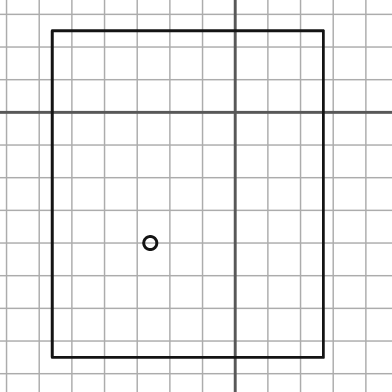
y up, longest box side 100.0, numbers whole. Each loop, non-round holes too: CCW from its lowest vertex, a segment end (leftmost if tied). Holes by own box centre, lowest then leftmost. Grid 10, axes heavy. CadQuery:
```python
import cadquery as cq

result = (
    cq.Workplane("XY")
    .moveTo(-56.0, -75.0)
    .lineTo(27.0, -75.0)
    .lineTo(27.0, 25.0)
    .lineTo(-56.0, 25.0)
    .close()
    .moveTo(-26.0, -40.0)
    .circle(2.0)
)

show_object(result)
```